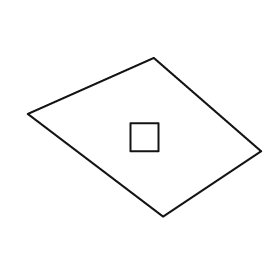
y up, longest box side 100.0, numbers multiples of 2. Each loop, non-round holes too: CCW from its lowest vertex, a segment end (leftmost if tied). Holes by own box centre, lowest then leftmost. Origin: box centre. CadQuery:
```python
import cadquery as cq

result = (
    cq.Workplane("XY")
    .moveTo(8.0, -34.0)
    .lineTo(50.0, -6.0)
    .lineTo(4.0, 34.0)
    .lineTo(-50.0, 10.0)
    .close()
    .moveTo(-6.0, -6.0)
    .lineTo(6.0, -6.0)
    .lineTo(6.0, 6.0)
    .lineTo(-6.0, 6.0)
    .close()
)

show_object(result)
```